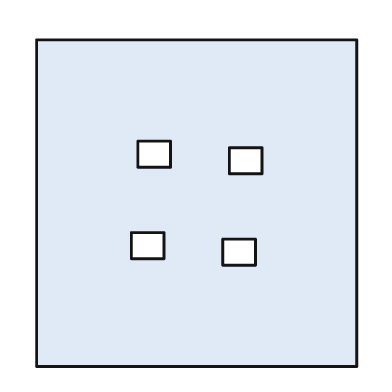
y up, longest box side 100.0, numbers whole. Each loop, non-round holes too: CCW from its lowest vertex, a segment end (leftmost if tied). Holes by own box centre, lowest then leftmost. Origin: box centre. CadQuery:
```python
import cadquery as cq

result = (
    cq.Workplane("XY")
    .moveTo(-49.0, -50.0)
    .lineTo(49.0, -50.0)
    .lineTo(49.0, 50.0)
    .lineTo(-49.0, 50.0)
    .close()
    .moveTo(8.0, -19.0)
    .lineTo(18.0, -19.0)
    .lineTo(18.0, -11.0)
    .lineTo(8.0, -11.0)
    .close()
    .moveTo(-20.0, -17.0)
    .lineTo(-10.0, -17.0)
    .lineTo(-10.0, -9.0)
    .lineTo(-20.0, -9.0)
    .close()
    .moveTo(10.0, 9.0)
    .lineTo(20.0, 9.0)
    .lineTo(20.0, 17.0)
    .lineTo(10.0, 17.0)
    .close()
    .moveTo(-18.0, 11.0)
    .lineTo(-8.0, 11.0)
    .lineTo(-8.0, 19.0)
    .lineTo(-18.0, 19.0)
    .close()
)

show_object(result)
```